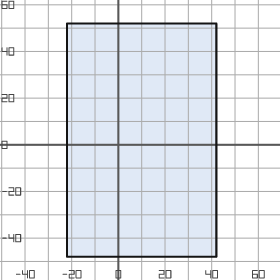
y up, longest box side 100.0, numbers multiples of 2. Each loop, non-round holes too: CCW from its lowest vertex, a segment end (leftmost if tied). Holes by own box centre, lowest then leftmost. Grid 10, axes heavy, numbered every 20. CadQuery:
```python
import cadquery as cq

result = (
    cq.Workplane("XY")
    .moveTo(-22.0, -48.0)
    .lineTo(42.0, -48.0)
    .lineTo(42.0, 52.0)
    .lineTo(-22.0, 52.0)
    .close()
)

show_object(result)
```